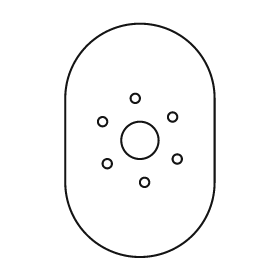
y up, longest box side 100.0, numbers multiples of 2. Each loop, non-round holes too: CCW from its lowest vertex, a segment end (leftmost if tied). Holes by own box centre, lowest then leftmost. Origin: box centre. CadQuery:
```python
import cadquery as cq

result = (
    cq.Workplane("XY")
    .moveTo(-32.0, -18.0)
    .threePointArc((0.0, -50.0), (32.0, -18.0))
    .lineTo(32.0, 18.0)
    .threePointArc((0.0, 50.0), (-32.0, 18.0))
    .close()
    .moveTo(2.0, -18.0)
    .circle(2.0)
    .moveTo(-14.0, -10.0)
    .circle(2.0)
    .moveTo(16.0, -8.0)
    .circle(2.0)
    .moveTo(0.0, 0.0)
    .circle(8.0)
    .moveTo(-16.0, 8.0)
    .circle(2.0)
    .moveTo(14.0, 10.0)
    .circle(2.0)
    .moveTo(-2.0, 18.0)
    .circle(2.0)
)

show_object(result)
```